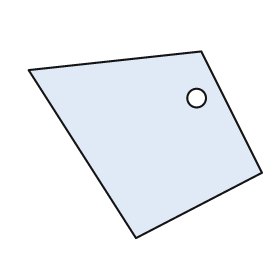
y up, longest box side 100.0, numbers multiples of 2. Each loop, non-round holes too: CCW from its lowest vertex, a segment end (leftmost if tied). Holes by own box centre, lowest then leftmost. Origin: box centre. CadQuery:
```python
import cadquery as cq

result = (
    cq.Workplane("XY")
    .moveTo(-4.0, -40.0)
    .lineTo(50.0, -12.0)
    .lineTo(24.0, 40.0)
    .lineTo(-50.0, 32.0)
    .close()
    .moveTo(22.0, 20.0)
    .circle(4.0)
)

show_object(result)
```